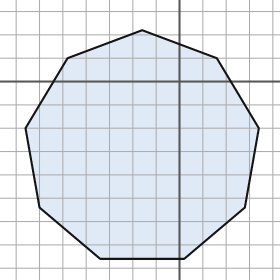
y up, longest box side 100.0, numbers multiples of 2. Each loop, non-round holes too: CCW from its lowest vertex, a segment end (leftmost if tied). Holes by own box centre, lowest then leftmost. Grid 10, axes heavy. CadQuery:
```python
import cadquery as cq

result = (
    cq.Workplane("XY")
    .moveTo(-34.0, -76.0)
    .lineTo(2.0, -76.0)
    .lineTo(28.0, -54.0)
    .lineTo(34.0, -20.0)
    .lineTo(16.0, 10.0)
    .lineTo(-16.0, 22.0)
    .lineTo(-48.0, 10.0)
    .lineTo(-66.0, -20.0)
    .lineTo(-60.0, -54.0)
    .close()
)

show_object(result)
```